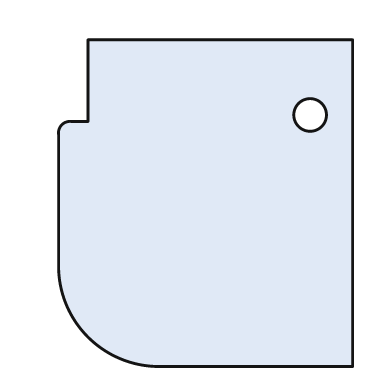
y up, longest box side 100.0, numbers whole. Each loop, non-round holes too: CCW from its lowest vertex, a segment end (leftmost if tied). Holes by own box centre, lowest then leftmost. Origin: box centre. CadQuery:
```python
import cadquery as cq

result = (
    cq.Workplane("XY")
    .moveTo(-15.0, -50.0)
    .lineTo(45.0, -50.0)
    .lineTo(45.0, 50.0)
    .lineTo(-36.0, 50.0)
    .lineTo(-36.0, 25.0)
    .lineTo(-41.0, 25.0)
    .threePointArc((-44.0, 24.0), (-45.0, 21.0))
    .lineTo(-45.0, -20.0)
    .threePointArc((-36.0, -41.0), (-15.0, -50.0))
    .close()
    .moveTo(32.0, 27.0)
    .circle(5.0)
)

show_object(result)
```